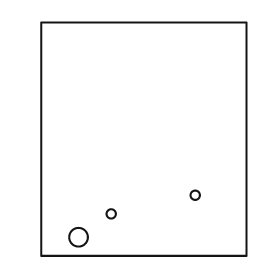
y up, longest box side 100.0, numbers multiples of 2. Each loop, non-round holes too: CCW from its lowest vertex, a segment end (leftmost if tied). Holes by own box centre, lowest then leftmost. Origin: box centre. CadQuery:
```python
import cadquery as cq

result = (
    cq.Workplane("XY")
    .moveTo(-44.0, -50.0)
    .lineTo(44.0, -50.0)
    .lineTo(44.0, 50.0)
    .lineTo(-44.0, 50.0)
    .close()
    .moveTo(-28.0, -42.0)
    .circle(4.0)
    .moveTo(-14.0, -32.0)
    .circle(2.0)
    .moveTo(22.0, -24.0)
    .circle(2.0)
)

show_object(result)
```